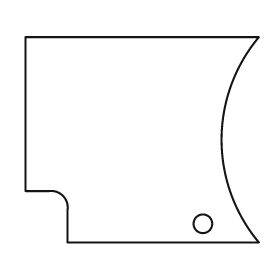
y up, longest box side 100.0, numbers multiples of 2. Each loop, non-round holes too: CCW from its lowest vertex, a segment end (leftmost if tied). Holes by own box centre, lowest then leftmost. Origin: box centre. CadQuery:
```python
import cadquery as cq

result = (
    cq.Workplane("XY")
    .moveTo(-32.0, -44.0)
    .lineTo(50.0, -44.0)
    .threePointArc((34.0, 0.0), (50.0, 44.0))
    .lineTo(-50.0, 44.0)
    .lineTo(-50.0, -22.0)
    .lineTo(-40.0, -22.0)
    .threePointArc((-34.0, -24.0), (-32.0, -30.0))
    .close()
    .moveTo(26.0, -36.0)
    .circle(4.0)
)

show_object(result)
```